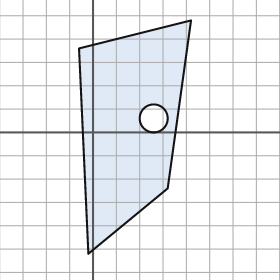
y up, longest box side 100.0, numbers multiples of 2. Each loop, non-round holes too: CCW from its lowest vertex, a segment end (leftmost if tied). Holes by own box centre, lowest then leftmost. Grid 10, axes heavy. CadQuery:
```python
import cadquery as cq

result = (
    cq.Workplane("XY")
    .moveTo(-2.0, -52.0)
    .lineTo(32.0, -24.0)
    .lineTo(42.0, 48.0)
    .lineTo(-6.0, 36.0)
    .close()
    .moveTo(26.0, 6.0)
    .circle(6.0)
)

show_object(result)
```